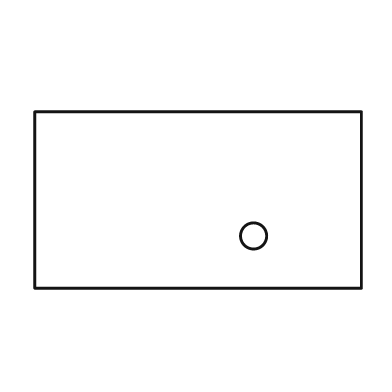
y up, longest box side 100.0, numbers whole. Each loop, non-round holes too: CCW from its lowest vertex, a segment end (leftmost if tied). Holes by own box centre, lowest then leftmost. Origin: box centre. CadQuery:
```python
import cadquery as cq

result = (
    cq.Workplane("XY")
    .moveTo(-50.0, -27.0)
    .lineTo(50.0, -27.0)
    .lineTo(50.0, 27.0)
    .lineTo(-50.0, 27.0)
    .close()
    .moveTo(17.0, -11.0)
    .circle(4.0)
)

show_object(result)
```